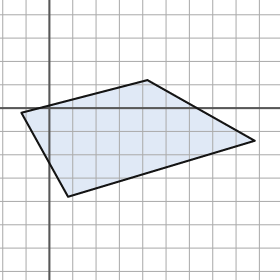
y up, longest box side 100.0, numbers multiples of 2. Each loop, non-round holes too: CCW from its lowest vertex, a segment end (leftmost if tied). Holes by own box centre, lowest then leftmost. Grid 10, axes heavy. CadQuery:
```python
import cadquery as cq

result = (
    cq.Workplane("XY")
    .moveTo(8.0, -38.0)
    .lineTo(88.0, -14.0)
    .lineTo(42.0, 12.0)
    .lineTo(-12.0, -2.0)
    .close()
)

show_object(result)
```